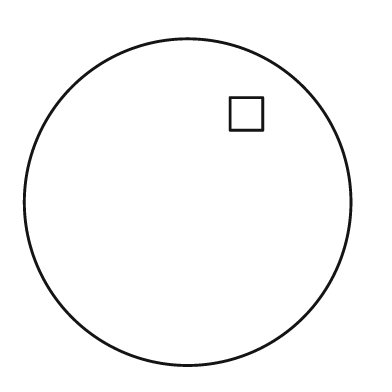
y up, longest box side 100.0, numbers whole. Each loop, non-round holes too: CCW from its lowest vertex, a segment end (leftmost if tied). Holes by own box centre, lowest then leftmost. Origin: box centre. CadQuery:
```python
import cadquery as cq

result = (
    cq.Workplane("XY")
    .moveTo(0.0, 0.0)
    .circle(50.0)
    .moveTo(13.0, 22.0)
    .lineTo(23.0, 22.0)
    .lineTo(23.0, 32.0)
    .lineTo(13.0, 32.0)
    .close()
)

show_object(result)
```